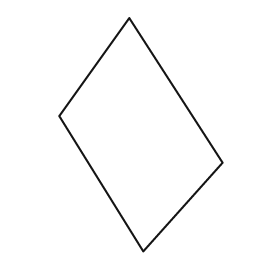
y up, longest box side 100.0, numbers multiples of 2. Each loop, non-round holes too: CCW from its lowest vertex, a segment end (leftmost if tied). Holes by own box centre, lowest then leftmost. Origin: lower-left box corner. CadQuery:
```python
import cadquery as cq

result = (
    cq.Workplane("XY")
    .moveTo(36.0, 0.0)
    .lineTo(70.0, 38.0)
    .lineTo(30.0, 100.0)
    .lineTo(0.0, 58.0)
    .close()
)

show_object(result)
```